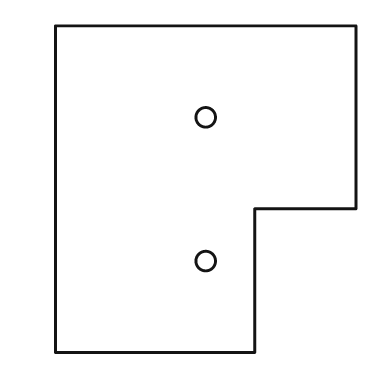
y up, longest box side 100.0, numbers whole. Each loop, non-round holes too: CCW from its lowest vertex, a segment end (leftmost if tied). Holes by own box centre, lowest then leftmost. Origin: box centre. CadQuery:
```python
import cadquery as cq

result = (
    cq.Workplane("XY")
    .moveTo(-46.0, -50.0)
    .lineTo(15.0, -50.0)
    .lineTo(15.0, -6.0)
    .lineTo(46.0, -6.0)
    .lineTo(46.0, 50.0)
    .lineTo(-46.0, 50.0)
    .close()
    .moveTo(0.0, -22.0)
    .circle(3.0)
    .moveTo(0.0, 22.0)
    .circle(3.0)
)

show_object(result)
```